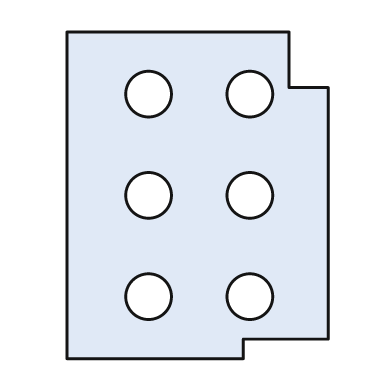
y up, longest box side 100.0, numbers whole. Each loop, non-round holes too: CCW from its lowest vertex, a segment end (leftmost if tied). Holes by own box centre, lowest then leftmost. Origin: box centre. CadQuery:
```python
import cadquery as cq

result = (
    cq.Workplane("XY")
    .moveTo(-40.0, -50.0)
    .lineTo(14.0, -50.0)
    .lineTo(14.0, -44.0)
    .lineTo(40.0, -44.0)
    .lineTo(40.0, 33.0)
    .lineTo(28.0, 33.0)
    .lineTo(28.0, 50.0)
    .lineTo(-40.0, 50.0)
    .close()
    .moveTo(-15.0, -31.0)
    .circle(7.0)
    .moveTo(16.0, -31.0)
    .circle(7.0)
    .moveTo(-15.0, 0.0)
    .circle(7.0)
    .moveTo(16.0, 0.0)
    .circle(7.0)
    .moveTo(-15.0, 31.0)
    .circle(7.0)
    .moveTo(16.0, 31.0)
    .circle(7.0)
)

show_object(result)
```